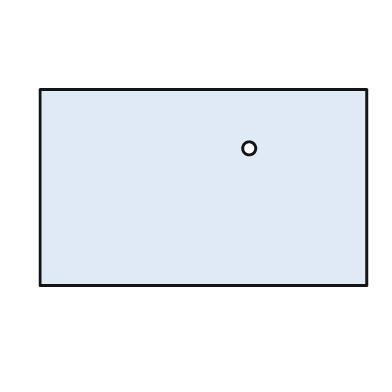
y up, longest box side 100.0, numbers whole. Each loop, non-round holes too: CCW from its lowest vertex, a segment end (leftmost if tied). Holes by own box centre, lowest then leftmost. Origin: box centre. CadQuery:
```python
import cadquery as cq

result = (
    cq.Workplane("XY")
    .moveTo(-50.0, -30.0)
    .lineTo(50.0, -30.0)
    .lineTo(50.0, 30.0)
    .lineTo(-50.0, 30.0)
    .close()
    .moveTo(14.0, 12.0)
    .circle(2.0)
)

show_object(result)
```